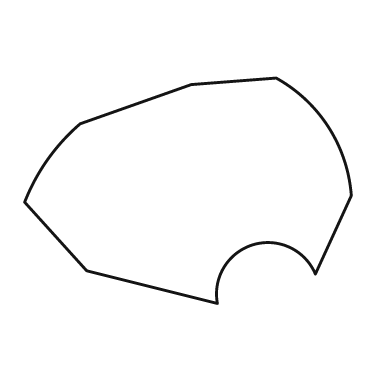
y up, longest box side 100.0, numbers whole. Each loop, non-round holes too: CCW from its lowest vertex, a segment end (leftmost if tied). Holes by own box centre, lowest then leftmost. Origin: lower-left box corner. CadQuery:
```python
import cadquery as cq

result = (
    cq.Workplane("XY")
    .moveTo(59.0, 0.0)
    .threePointArc((70.0, 18.0), (89.0, 9.0))
    .lineTo(100.0, 33.0)
    .threePointArc((93.0, 54.0), (77.0, 69.0))
    .lineTo(51.0, 67.0)
    .lineTo(17.0, 55.0)
    .threePointArc((7.0, 44.0), (0.0, 31.0))
    .lineTo(19.0, 10.0)
    .close()
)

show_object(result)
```